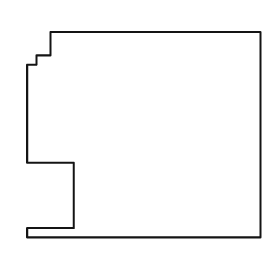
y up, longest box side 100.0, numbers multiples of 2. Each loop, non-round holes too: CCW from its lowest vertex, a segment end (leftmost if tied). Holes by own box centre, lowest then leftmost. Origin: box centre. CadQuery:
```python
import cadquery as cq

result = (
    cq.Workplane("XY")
    .moveTo(-50.0, -44.0)
    .lineTo(50.0, -44.0)
    .lineTo(50.0, 44.0)
    .lineTo(-40.0, 44.0)
    .lineTo(-40.0, 34.0)
    .lineTo(-46.0, 34.0)
    .lineTo(-46.0, 30.0)
    .lineTo(-50.0, 30.0)
    .lineTo(-50.0, -12.0)
    .lineTo(-30.0, -12.0)
    .lineTo(-30.0, -40.0)
    .lineTo(-50.0, -40.0)
    .close()
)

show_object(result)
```